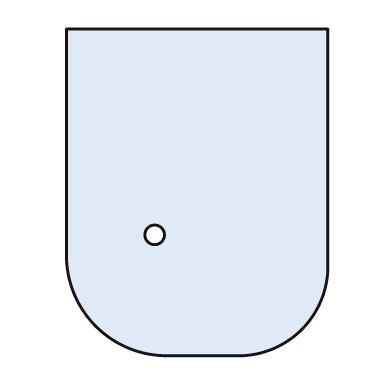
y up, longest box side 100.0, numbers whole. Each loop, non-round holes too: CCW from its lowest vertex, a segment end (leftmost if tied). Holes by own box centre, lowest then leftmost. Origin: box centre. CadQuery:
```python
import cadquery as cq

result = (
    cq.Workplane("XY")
    .moveTo(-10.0, -50.0)
    .lineTo(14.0, -50.0)
    .threePointArc((32.0, -42.0), (40.0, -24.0))
    .lineTo(40.0, 50.0)
    .lineTo(-40.0, 50.0)
    .lineTo(-40.0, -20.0)
    .threePointArc((-31.0, -41.0), (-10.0, -50.0))
    .close()
    .moveTo(-13.0, -13.0)
    .circle(3.0)
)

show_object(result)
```